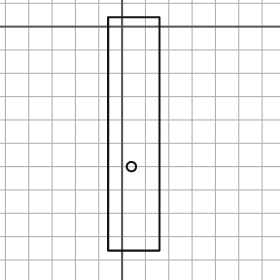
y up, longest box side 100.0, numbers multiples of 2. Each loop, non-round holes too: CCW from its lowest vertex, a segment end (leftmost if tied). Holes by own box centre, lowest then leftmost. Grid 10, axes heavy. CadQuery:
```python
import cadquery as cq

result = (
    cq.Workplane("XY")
    .moveTo(-6.0, -96.0)
    .lineTo(16.0, -96.0)
    .lineTo(16.0, 4.0)
    .lineTo(-6.0, 4.0)
    .close()
    .moveTo(4.0, -60.0)
    .circle(2.0)
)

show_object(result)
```